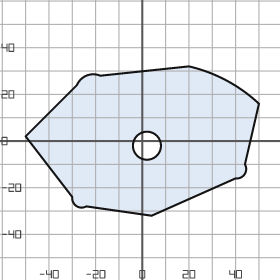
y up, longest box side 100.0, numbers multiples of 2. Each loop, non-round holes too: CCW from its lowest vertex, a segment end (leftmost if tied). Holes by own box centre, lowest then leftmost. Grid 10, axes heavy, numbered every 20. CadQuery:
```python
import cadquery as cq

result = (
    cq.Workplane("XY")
    .moveTo(4.0, -32.0)
    .lineTo(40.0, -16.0)
    .threePointArc((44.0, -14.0), (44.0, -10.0))
    .lineTo(50.0, 16.0)
    .threePointArc((36.0, 26.0), (20.0, 32.0))
    .lineTo(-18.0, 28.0)
    .threePointArc((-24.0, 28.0), (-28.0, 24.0))
    .lineTo(-50.0, 2.0)
    .lineTo(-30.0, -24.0)
    .threePointArc((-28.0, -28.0), (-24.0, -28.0))
    .close()
    .moveTo(2.0, -2.0)
    .circle(6.0)
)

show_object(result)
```